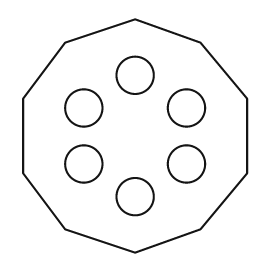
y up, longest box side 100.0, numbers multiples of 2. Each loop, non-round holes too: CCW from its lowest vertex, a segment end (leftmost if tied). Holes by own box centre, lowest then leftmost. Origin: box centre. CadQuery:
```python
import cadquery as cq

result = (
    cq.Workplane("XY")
    .moveTo(0.0, -50.0)
    .lineTo(28.0, -40.0)
    .lineTo(48.0, -16.0)
    .lineTo(48.0, 16.0)
    .lineTo(28.0, 40.0)
    .lineTo(0.0, 50.0)
    .lineTo(-30.0, 40.0)
    .lineTo(-48.0, 16.0)
    .lineTo(-48.0, -16.0)
    .lineTo(-30.0, -40.0)
    .close()
    .moveTo(0.0, -26.0)
    .circle(8.0)
    .moveTo(-22.0, -12.0)
    .circle(8.0)
    .moveTo(22.0, -12.0)
    .circle(8.0)
    .moveTo(-22.0, 12.0)
    .circle(8.0)
    .moveTo(22.0, 12.0)
    .circle(8.0)
    .moveTo(0.0, 26.0)
    .circle(8.0)
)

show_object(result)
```